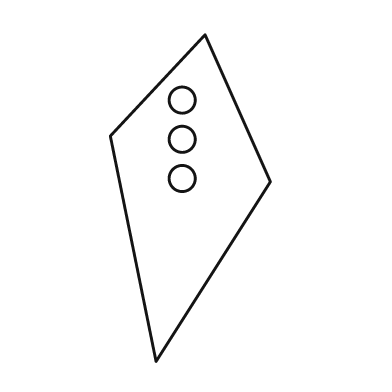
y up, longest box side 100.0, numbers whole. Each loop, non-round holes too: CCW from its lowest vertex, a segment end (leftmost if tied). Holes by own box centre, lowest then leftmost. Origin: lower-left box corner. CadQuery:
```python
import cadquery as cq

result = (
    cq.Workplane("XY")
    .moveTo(14.0, 0.0)
    .lineTo(49.0, 55.0)
    .lineTo(29.0, 100.0)
    .lineTo(0.0, 69.0)
    .close()
    .moveTo(22.0, 56.0)
    .circle(4.0)
    .moveTo(22.0, 68.0)
    .circle(4.0)
    .moveTo(22.0, 80.0)
    .circle(4.0)
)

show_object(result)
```